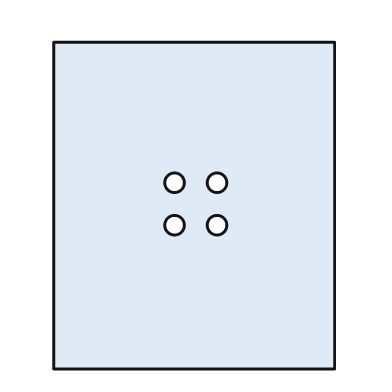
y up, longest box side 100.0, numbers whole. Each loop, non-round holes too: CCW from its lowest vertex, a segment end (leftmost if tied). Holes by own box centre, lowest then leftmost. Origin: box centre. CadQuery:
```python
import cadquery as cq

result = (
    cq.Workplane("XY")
    .moveTo(-43.0, -50.0)
    .lineTo(43.0, -50.0)
    .lineTo(43.0, 50.0)
    .lineTo(-43.0, 50.0)
    .close()
    .moveTo(-6.0, -6.0)
    .circle(3.0)
    .moveTo(7.0, -6.0)
    .circle(3.0)
    .moveTo(-6.0, 7.0)
    .circle(3.0)
    .moveTo(7.0, 7.0)
    .circle(3.0)
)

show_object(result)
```